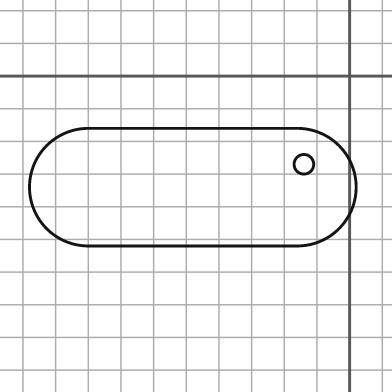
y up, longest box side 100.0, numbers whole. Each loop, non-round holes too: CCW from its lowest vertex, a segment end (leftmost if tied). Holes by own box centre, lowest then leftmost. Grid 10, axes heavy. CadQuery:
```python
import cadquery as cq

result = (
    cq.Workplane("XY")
    .moveTo(-80.0, -52.0)
    .lineTo(-16.0, -52.0)
    .threePointArc((2.0, -34.0), (-16.0, -16.0))
    .lineTo(-80.0, -16.0)
    .threePointArc((-98.0, -34.0), (-80.0, -52.0))
    .close()
    .moveTo(-14.0, -27.0)
    .circle(3.0)
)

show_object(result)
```